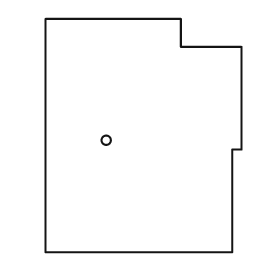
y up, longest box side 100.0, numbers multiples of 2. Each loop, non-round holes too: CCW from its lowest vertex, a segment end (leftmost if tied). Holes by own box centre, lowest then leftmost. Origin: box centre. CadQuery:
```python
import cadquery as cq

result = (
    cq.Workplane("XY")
    .moveTo(-42.0, -50.0)
    .lineTo(38.0, -50.0)
    .lineTo(38.0, -6.0)
    .lineTo(42.0, -6.0)
    .lineTo(42.0, 38.0)
    .lineTo(16.0, 38.0)
    .lineTo(16.0, 50.0)
    .lineTo(-42.0, 50.0)
    .close()
    .moveTo(-16.0, -2.0)
    .circle(2.0)
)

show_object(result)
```